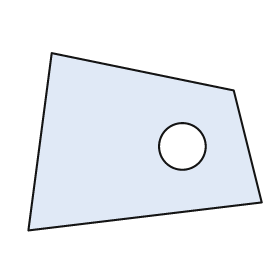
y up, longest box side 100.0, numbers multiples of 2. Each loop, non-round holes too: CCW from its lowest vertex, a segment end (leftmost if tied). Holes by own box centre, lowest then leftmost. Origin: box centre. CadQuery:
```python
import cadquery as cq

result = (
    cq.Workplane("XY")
    .moveTo(-50.0, -38.0)
    .lineTo(50.0, -26.0)
    .lineTo(38.0, 22.0)
    .lineTo(-40.0, 38.0)
    .close()
    .moveTo(16.0, -2.0)
    .circle(10.0)
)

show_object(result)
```